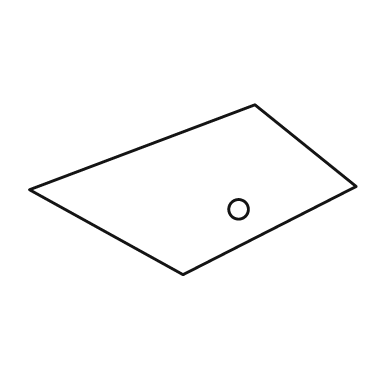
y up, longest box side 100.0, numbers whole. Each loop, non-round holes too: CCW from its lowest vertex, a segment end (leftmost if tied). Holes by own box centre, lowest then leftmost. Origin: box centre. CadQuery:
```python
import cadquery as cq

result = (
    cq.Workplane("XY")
    .moveTo(-3.0, -26.0)
    .lineTo(50.0, 1.0)
    .lineTo(19.0, 26.0)
    .lineTo(-50.0, 0.0)
    .close()
    .moveTo(14.0, -6.0)
    .circle(3.0)
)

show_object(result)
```